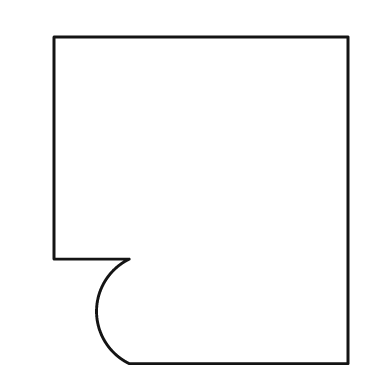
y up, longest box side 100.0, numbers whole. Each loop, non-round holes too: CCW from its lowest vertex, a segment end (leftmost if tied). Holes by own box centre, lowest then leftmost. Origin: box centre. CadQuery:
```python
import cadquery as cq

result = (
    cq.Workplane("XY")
    .moveTo(-22.0, -50.0)
    .lineTo(45.0, -50.0)
    .lineTo(45.0, 50.0)
    .lineTo(-45.0, 50.0)
    .lineTo(-45.0, -18.0)
    .lineTo(-22.0, -18.0)
    .threePointArc((-32.0, -34.0), (-22.0, -50.0))
    .close()
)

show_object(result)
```